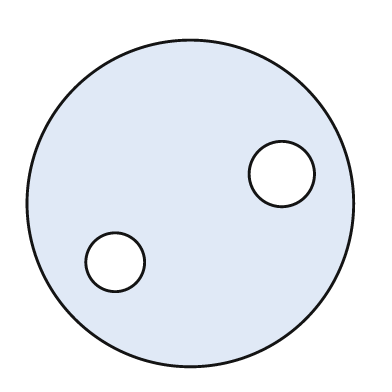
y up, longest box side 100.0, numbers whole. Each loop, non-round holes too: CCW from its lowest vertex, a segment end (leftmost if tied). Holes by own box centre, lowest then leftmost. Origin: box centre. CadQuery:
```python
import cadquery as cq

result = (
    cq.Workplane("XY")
    .moveTo(0.0, 0.0)
    .circle(50.0)
    .moveTo(-23.0, -18.0)
    .circle(9.0)
    .moveTo(28.0, 9.0)
    .circle(10.0)
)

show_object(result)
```